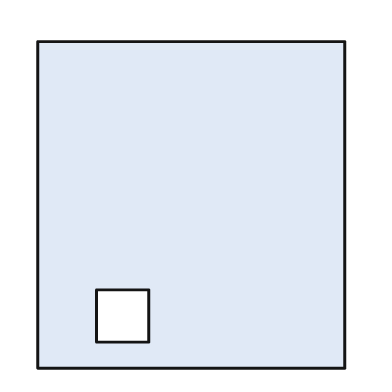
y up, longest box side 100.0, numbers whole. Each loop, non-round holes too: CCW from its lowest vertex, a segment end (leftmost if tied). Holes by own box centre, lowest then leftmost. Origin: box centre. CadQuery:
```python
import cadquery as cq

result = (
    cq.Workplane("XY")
    .moveTo(-47.0, -50.0)
    .lineTo(47.0, -50.0)
    .lineTo(47.0, 50.0)
    .lineTo(-47.0, 50.0)
    .close()
    .moveTo(-29.0, -42.0)
    .lineTo(-13.0, -42.0)
    .lineTo(-13.0, -26.0)
    .lineTo(-29.0, -26.0)
    .close()
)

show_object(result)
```